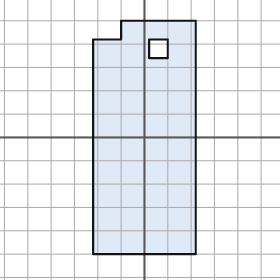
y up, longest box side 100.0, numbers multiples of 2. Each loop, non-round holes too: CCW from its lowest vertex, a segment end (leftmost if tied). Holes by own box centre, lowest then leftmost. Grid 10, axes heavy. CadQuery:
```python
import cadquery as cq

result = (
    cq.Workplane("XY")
    .moveTo(-22.0, -50.0)
    .lineTo(22.0, -50.0)
    .lineTo(22.0, 50.0)
    .lineTo(-10.0, 50.0)
    .lineTo(-10.0, 42.0)
    .lineTo(-22.0, 42.0)
    .close()
    .moveTo(2.0, 34.0)
    .lineTo(10.0, 34.0)
    .lineTo(10.0, 42.0)
    .lineTo(2.0, 42.0)
    .close()
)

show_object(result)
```